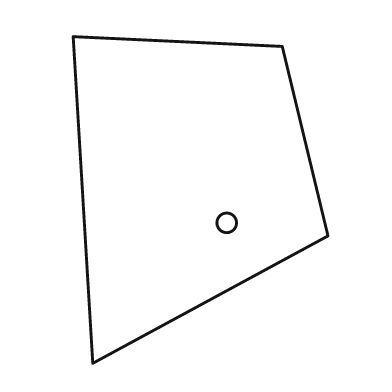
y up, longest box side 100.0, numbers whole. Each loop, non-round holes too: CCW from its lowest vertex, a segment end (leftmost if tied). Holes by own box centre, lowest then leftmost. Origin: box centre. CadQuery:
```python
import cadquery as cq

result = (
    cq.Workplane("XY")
    .moveTo(-33.0, -50.0)
    .lineTo(39.0, -11.0)
    .lineTo(25.0, 47.0)
    .lineTo(-39.0, 50.0)
    .close()
    .moveTo(8.0, -7.0)
    .circle(3.0)
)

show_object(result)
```